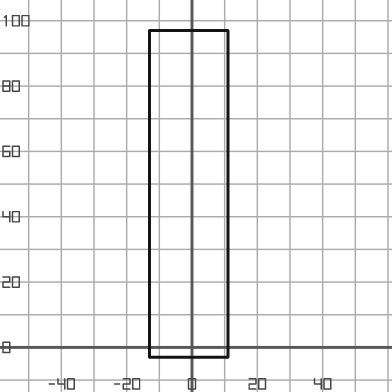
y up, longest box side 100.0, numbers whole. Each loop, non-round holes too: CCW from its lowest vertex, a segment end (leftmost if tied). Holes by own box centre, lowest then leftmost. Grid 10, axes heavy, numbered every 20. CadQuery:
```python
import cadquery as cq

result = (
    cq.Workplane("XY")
    .moveTo(-13.0, -3.0)
    .lineTo(11.0, -3.0)
    .lineTo(11.0, 97.0)
    .lineTo(-13.0, 97.0)
    .close()
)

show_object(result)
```